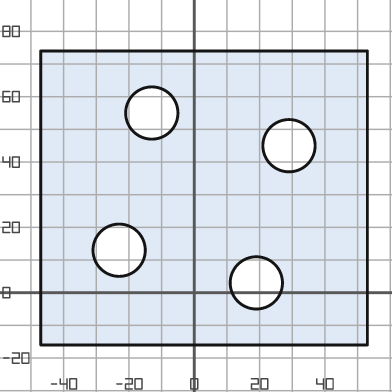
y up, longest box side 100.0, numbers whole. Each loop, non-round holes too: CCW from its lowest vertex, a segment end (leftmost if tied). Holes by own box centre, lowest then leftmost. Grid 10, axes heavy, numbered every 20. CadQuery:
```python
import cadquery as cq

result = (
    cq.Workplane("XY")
    .moveTo(-47.0, -16.0)
    .lineTo(53.0, -16.0)
    .lineTo(53.0, 74.0)
    .lineTo(-47.0, 74.0)
    .close()
    .moveTo(19.0, 3.0)
    .circle(8.0)
    .moveTo(-23.0, 13.0)
    .circle(8.0)
    .moveTo(29.0, 45.0)
    .circle(8.0)
    .moveTo(-13.0, 55.0)
    .circle(8.0)
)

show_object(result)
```